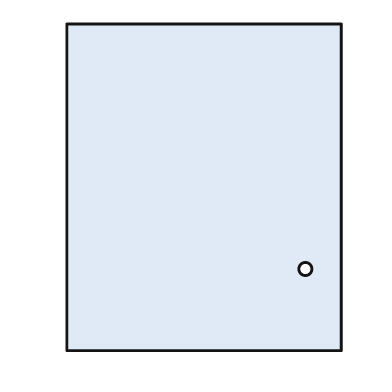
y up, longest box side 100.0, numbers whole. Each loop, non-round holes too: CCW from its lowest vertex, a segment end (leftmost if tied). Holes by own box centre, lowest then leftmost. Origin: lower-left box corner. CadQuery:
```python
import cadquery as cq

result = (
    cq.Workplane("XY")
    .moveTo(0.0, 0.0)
    .lineTo(84.0, 0.0)
    .lineTo(84.0, 100.0)
    .lineTo(0.0, 100.0)
    .close()
    .moveTo(73.0, 25.0)
    .circle(2.0)
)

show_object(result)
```